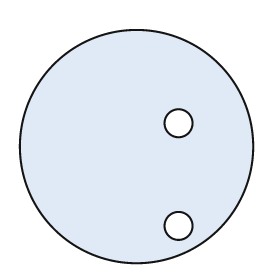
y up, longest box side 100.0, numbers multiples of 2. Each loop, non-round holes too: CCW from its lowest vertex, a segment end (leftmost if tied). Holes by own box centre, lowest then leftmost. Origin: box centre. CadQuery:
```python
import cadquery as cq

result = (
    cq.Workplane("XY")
    .moveTo(0.0, 0.0)
    .circle(50.0)
    .moveTo(18.0, -34.0)
    .circle(6.0)
    .moveTo(18.0, 10.0)
    .circle(6.0)
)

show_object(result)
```